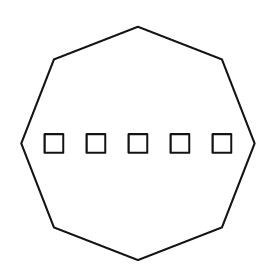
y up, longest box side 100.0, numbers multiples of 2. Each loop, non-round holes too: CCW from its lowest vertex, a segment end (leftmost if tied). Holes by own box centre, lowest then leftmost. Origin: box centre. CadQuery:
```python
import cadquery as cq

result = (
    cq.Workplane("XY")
    .moveTo(0.0, -50.0)
    .lineTo(36.0, -36.0)
    .lineTo(50.0, 0.0)
    .lineTo(36.0, 36.0)
    .lineTo(0.0, 50.0)
    .lineTo(-36.0, 36.0)
    .lineTo(-50.0, 0.0)
    .lineTo(-36.0, -36.0)
    .close()
    .moveTo(-40.0, -4.0)
    .lineTo(-32.0, -4.0)
    .lineTo(-32.0, 4.0)
    .lineTo(-40.0, 4.0)
    .close()
    .moveTo(-22.0, -4.0)
    .lineTo(-14.0, -4.0)
    .lineTo(-14.0, 4.0)
    .lineTo(-22.0, 4.0)
    .close()
    .moveTo(-4.0, -4.0)
    .lineTo(4.0, -4.0)
    .lineTo(4.0, 4.0)
    .lineTo(-4.0, 4.0)
    .close()
    .moveTo(14.0, -4.0)
    .lineTo(22.0, -4.0)
    .lineTo(22.0, 4.0)
    .lineTo(14.0, 4.0)
    .close()
    .moveTo(32.0, -4.0)
    .lineTo(40.0, -4.0)
    .lineTo(40.0, 4.0)
    .lineTo(32.0, 4.0)
    .close()
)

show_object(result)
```